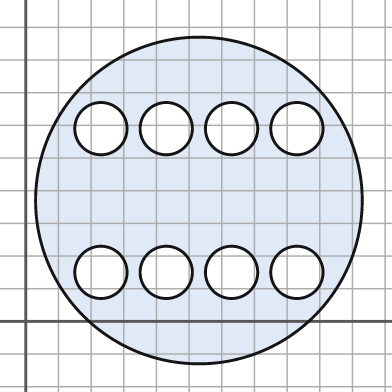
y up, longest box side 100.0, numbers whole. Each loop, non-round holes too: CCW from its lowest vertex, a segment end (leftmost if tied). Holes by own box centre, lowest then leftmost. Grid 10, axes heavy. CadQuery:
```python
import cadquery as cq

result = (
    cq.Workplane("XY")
    .moveTo(53.0, 37.0)
    .circle(50.0)
    .moveTo(23.0, 15.0)
    .circle(8.0)
    .moveTo(43.0, 15.0)
    .circle(8.0)
    .moveTo(63.0, 15.0)
    .circle(8.0)
    .moveTo(83.0, 15.0)
    .circle(8.0)
    .moveTo(23.0, 59.0)
    .circle(8.0)
    .moveTo(43.0, 59.0)
    .circle(8.0)
    .moveTo(63.0, 59.0)
    .circle(8.0)
    .moveTo(83.0, 59.0)
    .circle(8.0)
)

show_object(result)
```